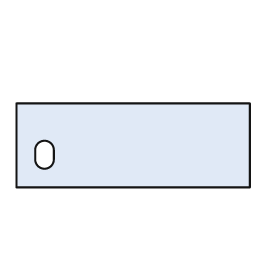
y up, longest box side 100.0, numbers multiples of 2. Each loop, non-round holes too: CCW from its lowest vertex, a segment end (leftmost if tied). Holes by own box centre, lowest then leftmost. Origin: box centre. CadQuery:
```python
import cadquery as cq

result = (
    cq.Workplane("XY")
    .moveTo(-50.0, -18.0)
    .lineTo(50.0, -18.0)
    .lineTo(50.0, 18.0)
    .lineTo(-50.0, 18.0)
    .close()
    .moveTo(-42.0, -6.0)
    .threePointArc((-38.0, -10.0), (-34.0, -6.0))
    .lineTo(-34.0, -2.0)
    .threePointArc((-38.0, 2.0), (-42.0, -2.0))
    .close()
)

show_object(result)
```